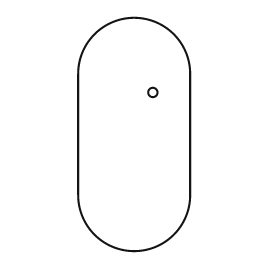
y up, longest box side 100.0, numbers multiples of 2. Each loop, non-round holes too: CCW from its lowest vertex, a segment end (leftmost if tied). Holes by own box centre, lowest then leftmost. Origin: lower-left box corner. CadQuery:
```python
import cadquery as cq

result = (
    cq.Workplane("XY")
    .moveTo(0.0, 24.0)
    .threePointArc((24.0, 0.0), (48.0, 24.0))
    .lineTo(48.0, 76.0)
    .threePointArc((24.0, 100.0), (0.0, 76.0))
    .close()
    .moveTo(32.0, 68.0)
    .circle(2.0)
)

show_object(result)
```